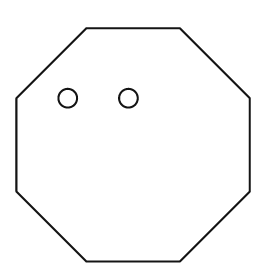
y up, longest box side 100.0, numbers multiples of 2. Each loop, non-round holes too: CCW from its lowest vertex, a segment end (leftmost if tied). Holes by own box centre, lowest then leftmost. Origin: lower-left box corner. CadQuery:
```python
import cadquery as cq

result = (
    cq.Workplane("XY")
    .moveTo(30.0, 0.0)
    .lineTo(70.0, 0.0)
    .lineTo(100.0, 30.0)
    .lineTo(100.0, 70.0)
    .lineTo(70.0, 100.0)
    .lineTo(30.0, 100.0)
    .lineTo(0.0, 70.0)
    .lineTo(0.0, 30.0)
    .close()
    .moveTo(22.0, 70.0)
    .circle(4.0)
    .moveTo(48.0, 70.0)
    .circle(4.0)
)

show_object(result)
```